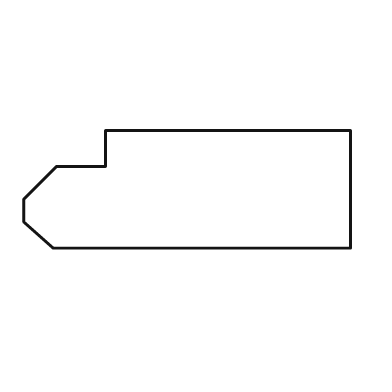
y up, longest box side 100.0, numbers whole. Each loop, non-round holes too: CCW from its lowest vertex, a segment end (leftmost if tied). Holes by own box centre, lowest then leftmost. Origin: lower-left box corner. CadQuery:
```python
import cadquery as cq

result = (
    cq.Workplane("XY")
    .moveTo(9.0, 0.0)
    .lineTo(100.0, 0.0)
    .lineTo(100.0, 36.0)
    .lineTo(25.0, 36.0)
    .lineTo(25.0, 25.0)
    .lineTo(10.0, 25.0)
    .lineTo(0.0, 15.0)
    .lineTo(0.0, 8.0)
    .close()
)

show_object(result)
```